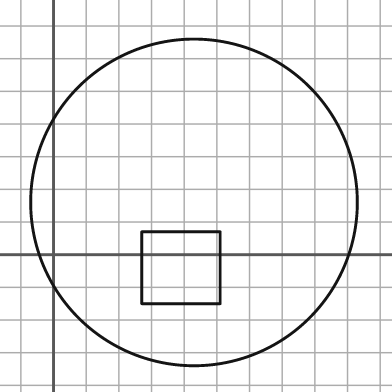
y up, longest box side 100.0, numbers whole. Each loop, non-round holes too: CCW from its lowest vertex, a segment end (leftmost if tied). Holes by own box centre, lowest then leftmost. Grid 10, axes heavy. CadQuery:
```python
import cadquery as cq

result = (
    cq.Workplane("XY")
    .moveTo(43.0, 16.0)
    .circle(50.0)
    .moveTo(27.0, -15.0)
    .lineTo(51.0, -15.0)
    .lineTo(51.0, 7.0)
    .lineTo(27.0, 7.0)
    .close()
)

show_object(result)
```